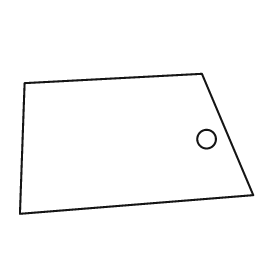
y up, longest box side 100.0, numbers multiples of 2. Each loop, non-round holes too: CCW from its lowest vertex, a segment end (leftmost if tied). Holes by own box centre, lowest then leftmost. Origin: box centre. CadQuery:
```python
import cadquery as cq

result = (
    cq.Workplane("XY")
    .moveTo(-50.0, -30.0)
    .lineTo(50.0, -22.0)
    .lineTo(28.0, 30.0)
    .lineTo(-48.0, 26.0)
    .close()
    .moveTo(30.0, 2.0)
    .circle(4.0)
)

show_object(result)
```